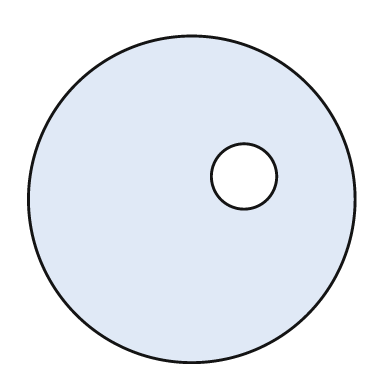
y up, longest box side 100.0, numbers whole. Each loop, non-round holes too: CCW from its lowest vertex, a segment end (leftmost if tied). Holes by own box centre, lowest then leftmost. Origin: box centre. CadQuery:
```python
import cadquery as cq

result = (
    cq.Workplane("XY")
    .moveTo(0.0, 0.0)
    .circle(50.0)
    .moveTo(16.0, 7.0)
    .circle(10.0)
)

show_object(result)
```